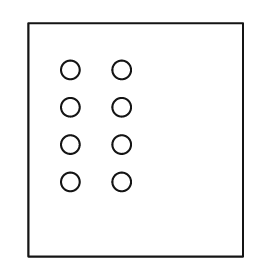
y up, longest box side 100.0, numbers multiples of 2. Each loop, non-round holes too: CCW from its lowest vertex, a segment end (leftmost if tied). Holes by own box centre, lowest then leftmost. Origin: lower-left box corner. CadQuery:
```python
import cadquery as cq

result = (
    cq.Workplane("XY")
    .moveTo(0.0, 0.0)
    .lineTo(92.0, 0.0)
    .lineTo(92.0, 100.0)
    .lineTo(0.0, 100.0)
    .close()
    .moveTo(18.0, 32.0)
    .circle(4.0)
    .moveTo(40.0, 32.0)
    .circle(4.0)
    .moveTo(18.0, 48.0)
    .circle(4.0)
    .moveTo(40.0, 48.0)
    .circle(4.0)
    .moveTo(18.0, 64.0)
    .circle(4.0)
    .moveTo(40.0, 64.0)
    .circle(4.0)
    .moveTo(18.0, 80.0)
    .circle(4.0)
    .moveTo(40.0, 80.0)
    .circle(4.0)
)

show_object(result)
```